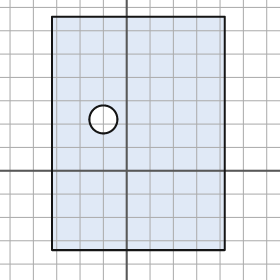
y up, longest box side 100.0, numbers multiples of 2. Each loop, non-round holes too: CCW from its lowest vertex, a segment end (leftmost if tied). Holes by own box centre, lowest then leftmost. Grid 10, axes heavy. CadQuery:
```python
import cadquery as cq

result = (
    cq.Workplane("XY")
    .moveTo(-32.0, -34.0)
    .lineTo(42.0, -34.0)
    .lineTo(42.0, 66.0)
    .lineTo(-32.0, 66.0)
    .close()
    .moveTo(-10.0, 22.0)
    .circle(6.0)
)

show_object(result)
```